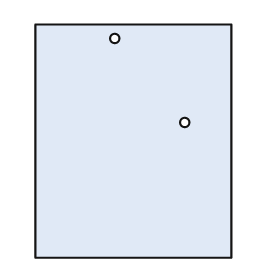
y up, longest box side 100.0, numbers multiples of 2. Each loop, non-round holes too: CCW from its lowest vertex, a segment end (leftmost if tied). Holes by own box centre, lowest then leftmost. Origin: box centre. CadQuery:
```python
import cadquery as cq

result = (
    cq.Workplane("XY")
    .moveTo(-42.0, -50.0)
    .lineTo(42.0, -50.0)
    .lineTo(42.0, 50.0)
    .lineTo(-42.0, 50.0)
    .close()
    .moveTo(22.0, 8.0)
    .circle(2.0)
    .moveTo(-8.0, 44.0)
    .circle(2.0)
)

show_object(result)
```